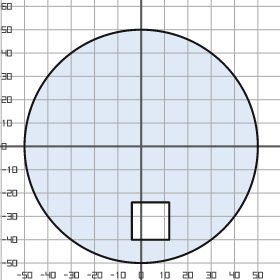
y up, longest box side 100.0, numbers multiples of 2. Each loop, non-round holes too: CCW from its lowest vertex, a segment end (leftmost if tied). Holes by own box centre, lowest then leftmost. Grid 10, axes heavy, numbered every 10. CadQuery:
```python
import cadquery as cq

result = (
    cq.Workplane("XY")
    .moveTo(0.0, 0.0)
    .circle(50.0)
    .moveTo(-4.0, -40.0)
    .lineTo(12.0, -40.0)
    .lineTo(12.0, -24.0)
    .lineTo(-4.0, -24.0)
    .close()
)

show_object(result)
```